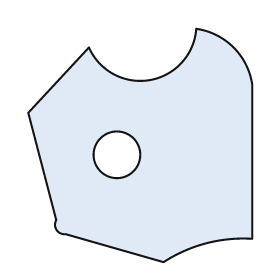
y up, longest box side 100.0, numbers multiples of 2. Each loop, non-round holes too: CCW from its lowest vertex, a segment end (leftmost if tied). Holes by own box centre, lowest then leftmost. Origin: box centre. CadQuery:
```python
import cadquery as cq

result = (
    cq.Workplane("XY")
    .moveTo(10.0, -50.0)
    .threePointArc((28.0, -42.0), (48.0, -40.0))
    .lineTo(48.0, 26.0)
    .threePointArc((40.0, 42.0), (24.0, 50.0))
    .threePointArc((4.0, 28.0), (-22.0, 42.0))
    .lineTo(-48.0, 14.0)
    .lineTo(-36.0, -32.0)
    .threePointArc((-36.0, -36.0), (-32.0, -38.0))
    .close()
    .moveTo(-10.0, -4.0)
    .circle(10.0)
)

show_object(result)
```